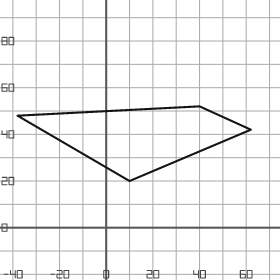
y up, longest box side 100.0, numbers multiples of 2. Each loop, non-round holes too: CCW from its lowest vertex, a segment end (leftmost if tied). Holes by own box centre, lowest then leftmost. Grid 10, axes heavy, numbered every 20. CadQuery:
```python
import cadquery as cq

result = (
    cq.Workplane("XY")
    .moveTo(10.0, 20.0)
    .lineTo(62.0, 42.0)
    .lineTo(40.0, 52.0)
    .lineTo(-38.0, 48.0)
    .close()
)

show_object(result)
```